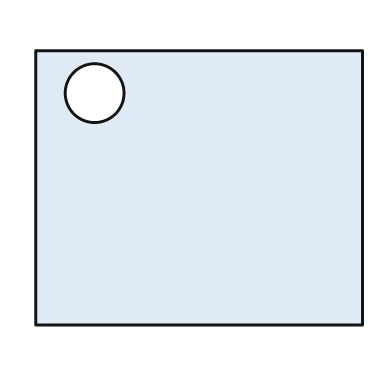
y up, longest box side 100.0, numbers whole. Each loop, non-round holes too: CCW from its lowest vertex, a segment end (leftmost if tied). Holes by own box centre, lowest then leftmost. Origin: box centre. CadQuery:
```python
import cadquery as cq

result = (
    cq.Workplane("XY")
    .moveTo(-50.0, -42.0)
    .lineTo(50.0, -42.0)
    .lineTo(50.0, 42.0)
    .lineTo(-50.0, 42.0)
    .close()
    .moveTo(-32.0, 29.0)
    .circle(9.0)
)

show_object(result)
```